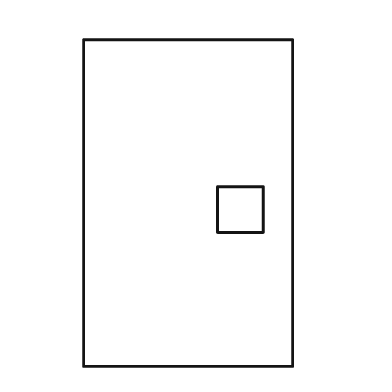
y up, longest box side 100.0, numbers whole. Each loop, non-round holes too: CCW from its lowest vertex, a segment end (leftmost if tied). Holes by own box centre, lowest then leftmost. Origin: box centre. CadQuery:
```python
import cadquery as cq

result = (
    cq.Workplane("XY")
    .moveTo(-32.0, -50.0)
    .lineTo(32.0, -50.0)
    .lineTo(32.0, 50.0)
    .lineTo(-32.0, 50.0)
    .close()
    .moveTo(9.0, -9.0)
    .lineTo(23.0, -9.0)
    .lineTo(23.0, 5.0)
    .lineTo(9.0, 5.0)
    .close()
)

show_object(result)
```